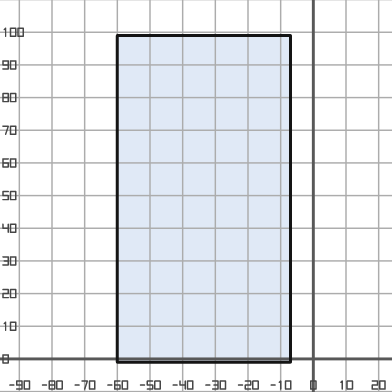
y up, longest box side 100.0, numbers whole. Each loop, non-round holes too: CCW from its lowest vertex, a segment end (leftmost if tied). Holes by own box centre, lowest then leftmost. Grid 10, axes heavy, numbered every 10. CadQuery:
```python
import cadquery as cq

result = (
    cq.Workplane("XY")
    .moveTo(-60.0, -1.0)
    .lineTo(-7.0, -1.0)
    .lineTo(-7.0, 99.0)
    .lineTo(-60.0, 99.0)
    .close()
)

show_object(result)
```